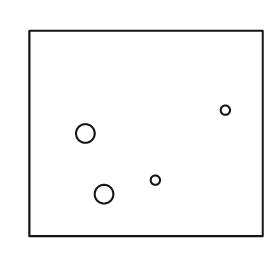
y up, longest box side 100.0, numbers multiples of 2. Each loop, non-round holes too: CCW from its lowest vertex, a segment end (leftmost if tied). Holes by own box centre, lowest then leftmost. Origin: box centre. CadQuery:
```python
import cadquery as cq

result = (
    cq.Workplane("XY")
    .moveTo(-50.0, -44.0)
    .lineTo(50.0, -44.0)
    .lineTo(50.0, 44.0)
    .lineTo(-50.0, 44.0)
    .close()
    .moveTo(-18.0, -26.0)
    .circle(4.0)
    .moveTo(4.0, -20.0)
    .circle(2.0)
    .moveTo(-26.0, 0.0)
    .circle(4.0)
    .moveTo(34.0, 10.0)
    .circle(2.0)
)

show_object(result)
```